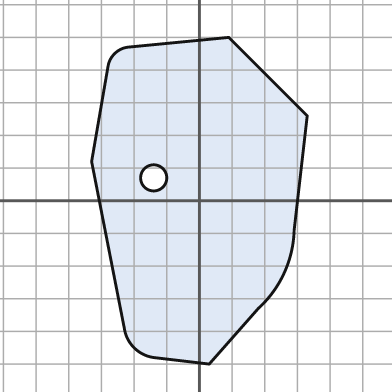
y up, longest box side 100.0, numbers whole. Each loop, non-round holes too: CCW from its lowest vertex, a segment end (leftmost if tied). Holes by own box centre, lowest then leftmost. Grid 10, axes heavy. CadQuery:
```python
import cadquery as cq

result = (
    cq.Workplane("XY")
    .moveTo(3.0, -50.0)
    .lineTo(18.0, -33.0)
    .threePointArc((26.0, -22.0), (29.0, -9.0))
    .lineTo(33.0, 26.0)
    .lineTo(9.0, 50.0)
    .lineTo(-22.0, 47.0)
    .threePointArc((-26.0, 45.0), (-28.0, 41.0))
    .lineTo(-33.0, 12.0)
    .lineTo(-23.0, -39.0)
    .threePointArc((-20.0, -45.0), (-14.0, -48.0))
    .close()
    .moveTo(-14.0, 7.0)
    .circle(4.0)
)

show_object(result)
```